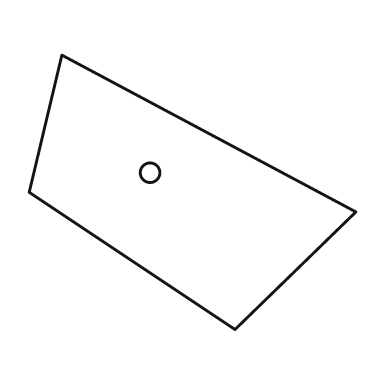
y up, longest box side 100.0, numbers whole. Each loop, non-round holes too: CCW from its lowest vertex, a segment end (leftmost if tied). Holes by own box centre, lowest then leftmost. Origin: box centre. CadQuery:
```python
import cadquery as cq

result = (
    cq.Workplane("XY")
    .moveTo(13.0, -42.0)
    .lineTo(50.0, -6.0)
    .lineTo(-40.0, 42.0)
    .lineTo(-50.0, 0.0)
    .close()
    .moveTo(-13.0, 6.0)
    .circle(3.0)
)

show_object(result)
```